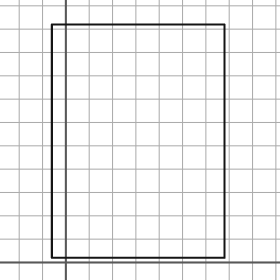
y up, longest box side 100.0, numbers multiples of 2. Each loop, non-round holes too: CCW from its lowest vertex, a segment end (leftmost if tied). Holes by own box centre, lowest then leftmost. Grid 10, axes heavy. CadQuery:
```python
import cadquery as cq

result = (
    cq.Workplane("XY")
    .moveTo(-6.0, 2.0)
    .lineTo(68.0, 2.0)
    .lineTo(68.0, 102.0)
    .lineTo(-6.0, 102.0)
    .close()
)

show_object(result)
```